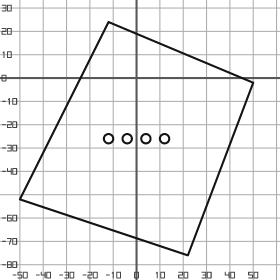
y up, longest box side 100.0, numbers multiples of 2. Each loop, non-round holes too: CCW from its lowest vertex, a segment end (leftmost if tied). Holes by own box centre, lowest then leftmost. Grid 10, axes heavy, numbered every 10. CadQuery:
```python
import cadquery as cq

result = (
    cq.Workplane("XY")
    .moveTo(22.0, -76.0)
    .lineTo(50.0, -2.0)
    .lineTo(-12.0, 24.0)
    .lineTo(-50.0, -52.0)
    .close()
    .moveTo(-12.0, -26.0)
    .circle(2.0)
    .moveTo(-4.0, -26.0)
    .circle(2.0)
    .moveTo(4.0, -26.0)
    .circle(2.0)
    .moveTo(12.0, -26.0)
    .circle(2.0)
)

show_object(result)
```